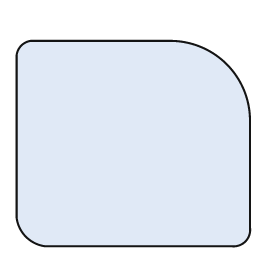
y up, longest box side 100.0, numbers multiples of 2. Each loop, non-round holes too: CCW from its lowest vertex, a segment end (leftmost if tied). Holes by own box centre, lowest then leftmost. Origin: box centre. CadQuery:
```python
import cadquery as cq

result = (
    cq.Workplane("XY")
    .moveTo(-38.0, -44.0)
    .lineTo(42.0, -44.0)
    .threePointArc((48.0, -42.0), (50.0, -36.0))
    .lineTo(50.0, 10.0)
    .threePointArc((40.0, 34.0), (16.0, 44.0))
    .lineTo(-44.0, 44.0)
    .threePointArc((-48.0, 42.0), (-50.0, 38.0))
    .lineTo(-50.0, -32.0)
    .threePointArc((-46.0, -40.0), (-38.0, -44.0))
    .close()
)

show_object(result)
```